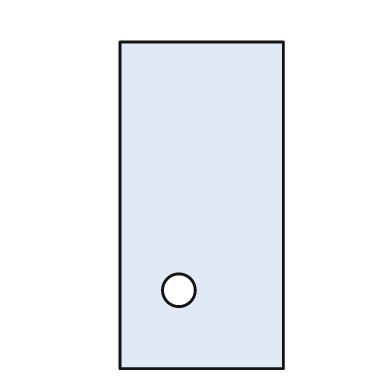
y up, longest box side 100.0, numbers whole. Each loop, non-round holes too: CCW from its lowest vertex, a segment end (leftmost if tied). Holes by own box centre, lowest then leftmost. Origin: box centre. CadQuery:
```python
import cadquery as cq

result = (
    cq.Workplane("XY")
    .moveTo(-25.0, -50.0)
    .lineTo(25.0, -50.0)
    .lineTo(25.0, 50.0)
    .lineTo(-25.0, 50.0)
    .close()
    .moveTo(-7.0, -26.0)
    .circle(5.0)
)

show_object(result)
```